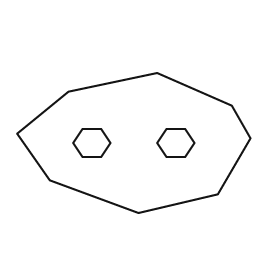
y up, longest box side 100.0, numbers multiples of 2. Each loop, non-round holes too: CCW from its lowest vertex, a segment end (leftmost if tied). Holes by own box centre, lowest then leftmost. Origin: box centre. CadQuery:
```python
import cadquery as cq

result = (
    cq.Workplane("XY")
    .moveTo(2.0, -30.0)
    .lineTo(36.0, -22.0)
    .lineTo(50.0, 2.0)
    .lineTo(42.0, 16.0)
    .lineTo(10.0, 30.0)
    .lineTo(-28.0, 22.0)
    .lineTo(-50.0, 4.0)
    .lineTo(-36.0, -16.0)
    .close()
    .moveTo(-22.0, -6.0)
    .lineTo(-14.0, -6.0)
    .lineTo(-10.0, 0.0)
    .lineTo(-14.0, 6.0)
    .lineTo(-22.0, 6.0)
    .lineTo(-26.0, 0.0)
    .close()
    .moveTo(14.0, -6.0)
    .lineTo(22.0, -6.0)
    .lineTo(26.0, 0.0)
    .lineTo(22.0, 6.0)
    .lineTo(14.0, 6.0)
    .lineTo(10.0, 0.0)
    .close()
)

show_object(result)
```